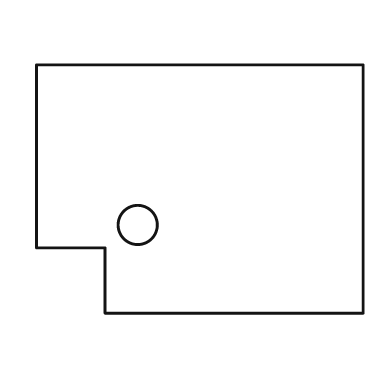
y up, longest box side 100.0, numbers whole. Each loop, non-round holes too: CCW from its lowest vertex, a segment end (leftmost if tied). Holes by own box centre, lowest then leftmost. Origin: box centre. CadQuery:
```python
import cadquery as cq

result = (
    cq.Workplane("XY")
    .moveTo(-29.0, -38.0)
    .lineTo(50.0, -38.0)
    .lineTo(50.0, 38.0)
    .lineTo(-50.0, 38.0)
    .lineTo(-50.0, -18.0)
    .lineTo(-29.0, -18.0)
    .close()
    .moveTo(-19.0, -11.0)
    .circle(6.0)
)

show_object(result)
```